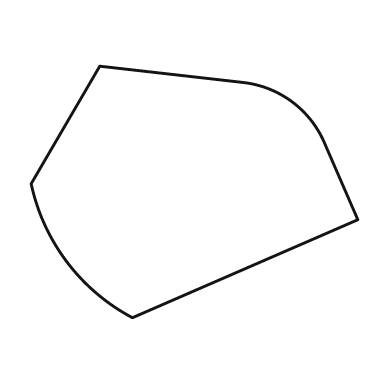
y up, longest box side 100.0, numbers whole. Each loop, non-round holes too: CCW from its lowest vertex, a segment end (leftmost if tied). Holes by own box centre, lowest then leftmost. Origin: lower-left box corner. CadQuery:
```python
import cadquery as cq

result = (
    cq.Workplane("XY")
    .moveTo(31.0, 0.0)
    .lineTo(100.0, 30.0)
    .lineTo(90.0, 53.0)
    .threePointArc((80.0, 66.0), (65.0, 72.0))
    .lineTo(21.0, 77.0)
    .lineTo(0.0, 41.0)
    .threePointArc((11.0, 17.0), (31.0, 0.0))
    .close()
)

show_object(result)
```